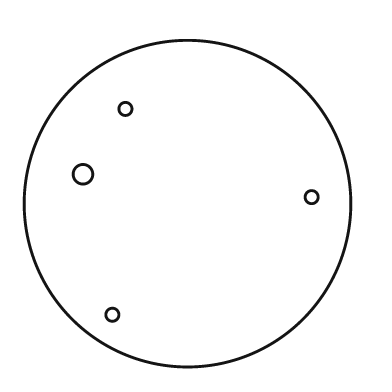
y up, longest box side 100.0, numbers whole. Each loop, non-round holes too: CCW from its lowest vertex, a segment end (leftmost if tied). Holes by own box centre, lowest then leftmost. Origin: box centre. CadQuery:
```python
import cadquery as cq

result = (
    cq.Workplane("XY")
    .moveTo(0.0, 0.0)
    .circle(50.0)
    .moveTo(-23.0, -34.0)
    .circle(2.0)
    .moveTo(38.0, 2.0)
    .circle(2.0)
    .moveTo(-32.0, 9.0)
    .circle(3.0)
    .moveTo(-19.0, 29.0)
    .circle(2.0)
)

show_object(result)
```